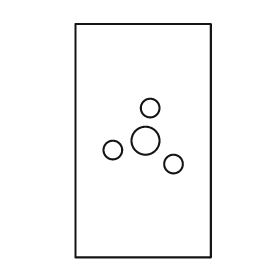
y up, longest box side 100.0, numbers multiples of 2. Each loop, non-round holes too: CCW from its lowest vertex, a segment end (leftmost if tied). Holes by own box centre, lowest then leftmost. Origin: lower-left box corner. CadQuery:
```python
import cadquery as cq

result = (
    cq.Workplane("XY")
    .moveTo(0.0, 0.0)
    .lineTo(58.0, 0.0)
    .lineTo(58.0, 100.0)
    .lineTo(0.0, 100.0)
    .close()
    .moveTo(42.0, 40.0)
    .circle(4.0)
    .moveTo(16.0, 46.0)
    .circle(4.0)
    .moveTo(30.0, 50.0)
    .circle(6.0)
    .moveTo(32.0, 64.0)
    .circle(4.0)
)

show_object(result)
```